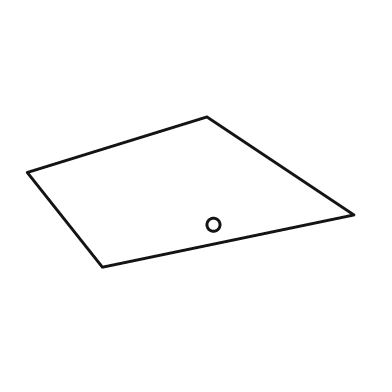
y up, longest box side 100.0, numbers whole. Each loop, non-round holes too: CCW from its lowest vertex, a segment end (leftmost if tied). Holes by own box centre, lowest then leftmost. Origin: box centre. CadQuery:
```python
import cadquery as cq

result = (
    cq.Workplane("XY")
    .moveTo(-27.0, -23.0)
    .lineTo(50.0, -7.0)
    .lineTo(5.0, 23.0)
    .lineTo(-50.0, 6.0)
    .close()
    .moveTo(7.0, -10.0)
    .circle(2.0)
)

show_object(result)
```